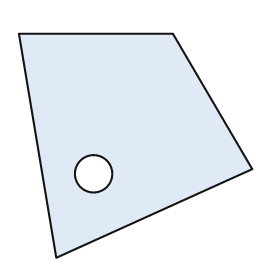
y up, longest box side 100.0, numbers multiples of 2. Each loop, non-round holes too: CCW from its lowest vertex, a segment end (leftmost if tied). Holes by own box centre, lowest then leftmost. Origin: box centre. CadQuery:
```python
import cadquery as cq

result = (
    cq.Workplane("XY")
    .moveTo(-34.0, -48.0)
    .lineTo(50.0, -10.0)
    .lineTo(16.0, 48.0)
    .lineTo(-50.0, 48.0)
    .close()
    .moveTo(-18.0, -12.0)
    .circle(8.0)
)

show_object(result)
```